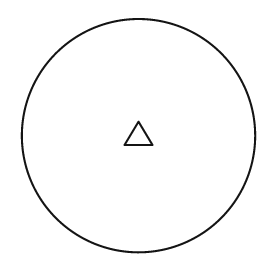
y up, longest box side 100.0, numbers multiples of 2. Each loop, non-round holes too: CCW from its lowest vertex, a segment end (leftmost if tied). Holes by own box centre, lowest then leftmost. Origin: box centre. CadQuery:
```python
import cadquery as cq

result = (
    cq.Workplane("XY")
    .moveTo(0.0, 0.0)
    .circle(50.0)
    .moveTo(-6.0, -4.0)
    .lineTo(6.0, -4.0)
    .lineTo(0.0, 6.0)
    .close()
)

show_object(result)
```